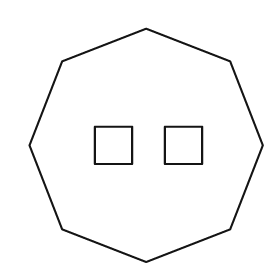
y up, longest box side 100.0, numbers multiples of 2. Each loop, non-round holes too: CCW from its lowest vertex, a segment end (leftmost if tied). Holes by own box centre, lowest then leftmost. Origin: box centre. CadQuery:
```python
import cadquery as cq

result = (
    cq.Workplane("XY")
    .moveTo(0.0, -50.0)
    .lineTo(36.0, -36.0)
    .lineTo(50.0, 0.0)
    .lineTo(36.0, 36.0)
    .lineTo(0.0, 50.0)
    .lineTo(-36.0, 36.0)
    .lineTo(-50.0, 0.0)
    .lineTo(-36.0, -36.0)
    .close()
    .moveTo(-22.0, -8.0)
    .lineTo(-6.0, -8.0)
    .lineTo(-6.0, 8.0)
    .lineTo(-22.0, 8.0)
    .close()
    .moveTo(8.0, -8.0)
    .lineTo(24.0, -8.0)
    .lineTo(24.0, 8.0)
    .lineTo(8.0, 8.0)
    .close()
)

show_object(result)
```